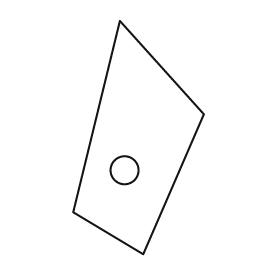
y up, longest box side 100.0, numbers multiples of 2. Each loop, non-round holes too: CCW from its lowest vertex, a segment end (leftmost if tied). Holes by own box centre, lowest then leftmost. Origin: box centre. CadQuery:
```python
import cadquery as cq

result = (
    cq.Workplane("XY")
    .moveTo(2.0, -50.0)
    .lineTo(28.0, 10.0)
    .lineTo(-8.0, 50.0)
    .lineTo(-28.0, -32.0)
    .close()
    .moveTo(-6.0, -14.0)
    .circle(6.0)
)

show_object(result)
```